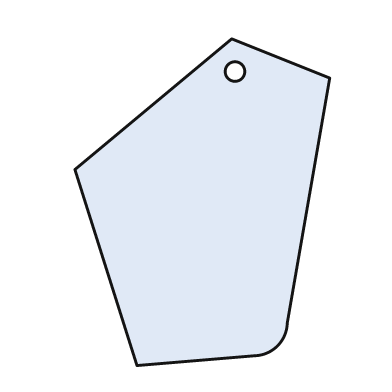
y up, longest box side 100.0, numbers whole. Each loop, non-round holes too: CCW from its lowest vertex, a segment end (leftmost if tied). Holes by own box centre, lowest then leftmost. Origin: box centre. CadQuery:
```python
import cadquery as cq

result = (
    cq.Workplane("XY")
    .moveTo(-20.0, -50.0)
    .lineTo(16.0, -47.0)
    .threePointArc((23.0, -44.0), (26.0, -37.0))
    .lineTo(39.0, 38.0)
    .lineTo(9.0, 50.0)
    .lineTo(-39.0, 10.0)
    .close()
    .moveTo(10.0, 40.0)
    .circle(3.0)
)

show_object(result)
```